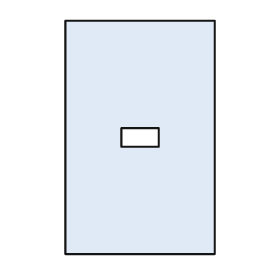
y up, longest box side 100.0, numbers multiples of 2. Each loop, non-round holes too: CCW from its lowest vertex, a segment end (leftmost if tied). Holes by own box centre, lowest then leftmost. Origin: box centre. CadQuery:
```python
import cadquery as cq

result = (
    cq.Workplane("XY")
    .moveTo(-32.0, -50.0)
    .lineTo(32.0, -50.0)
    .lineTo(32.0, 50.0)
    .lineTo(-32.0, 50.0)
    .close()
    .moveTo(-8.0, -4.0)
    .lineTo(8.0, -4.0)
    .lineTo(8.0, 4.0)
    .lineTo(-8.0, 4.0)
    .close()
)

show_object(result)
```